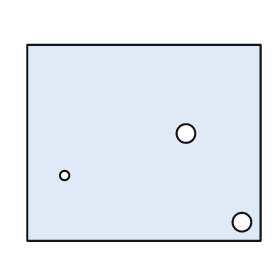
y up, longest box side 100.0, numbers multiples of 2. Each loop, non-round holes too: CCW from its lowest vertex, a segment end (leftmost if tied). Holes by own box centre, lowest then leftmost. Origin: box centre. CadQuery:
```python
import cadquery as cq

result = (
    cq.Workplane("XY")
    .moveTo(-50.0, -42.0)
    .lineTo(50.0, -42.0)
    .lineTo(50.0, 42.0)
    .lineTo(-50.0, 42.0)
    .close()
    .moveTo(42.0, -34.0)
    .circle(4.0)
    .moveTo(-34.0, -14.0)
    .circle(2.0)
    .moveTo(18.0, 4.0)
    .circle(4.0)
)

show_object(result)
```